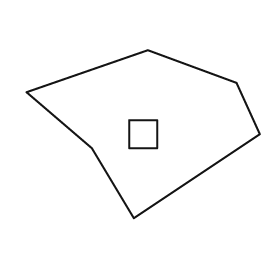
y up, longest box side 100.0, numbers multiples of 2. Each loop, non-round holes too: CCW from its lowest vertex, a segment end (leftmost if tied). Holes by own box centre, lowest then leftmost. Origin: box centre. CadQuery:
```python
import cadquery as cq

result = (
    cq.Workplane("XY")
    .moveTo(-4.0, -36.0)
    .lineTo(50.0, 0.0)
    .lineTo(40.0, 22.0)
    .lineTo(2.0, 36.0)
    .lineTo(-50.0, 18.0)
    .lineTo(-22.0, -6.0)
    .close()
    .moveTo(-6.0, -6.0)
    .lineTo(6.0, -6.0)
    .lineTo(6.0, 6.0)
    .lineTo(-6.0, 6.0)
    .close()
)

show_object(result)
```